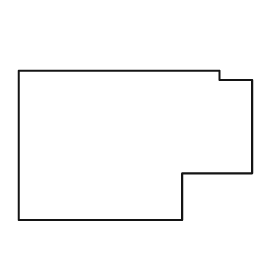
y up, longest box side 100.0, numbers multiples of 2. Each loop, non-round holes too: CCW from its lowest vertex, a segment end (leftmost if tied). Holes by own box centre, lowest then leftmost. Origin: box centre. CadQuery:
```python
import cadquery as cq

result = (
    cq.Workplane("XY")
    .moveTo(-50.0, -32.0)
    .lineTo(20.0, -32.0)
    .lineTo(20.0, -12.0)
    .lineTo(50.0, -12.0)
    .lineTo(50.0, 28.0)
    .lineTo(36.0, 28.0)
    .lineTo(36.0, 32.0)
    .lineTo(-50.0, 32.0)
    .close()
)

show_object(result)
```